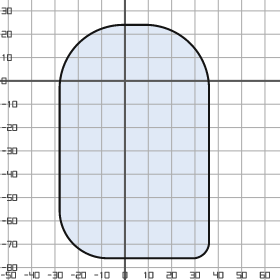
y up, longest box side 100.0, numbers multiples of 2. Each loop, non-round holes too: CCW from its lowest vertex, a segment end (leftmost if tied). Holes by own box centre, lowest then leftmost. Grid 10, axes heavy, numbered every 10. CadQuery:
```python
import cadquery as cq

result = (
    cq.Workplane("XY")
    .moveTo(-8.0, -76.0)
    .lineTo(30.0, -76.0)
    .threePointArc((34.0, -74.0), (36.0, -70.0))
    .lineTo(36.0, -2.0)
    .threePointArc((28.0, 16.0), (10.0, 24.0))
    .lineTo(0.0, 24.0)
    .threePointArc((-20.0, 16.0), (-28.0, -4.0))
    .lineTo(-28.0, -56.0)
    .threePointArc((-22.0, -70.0), (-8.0, -76.0))
    .close()
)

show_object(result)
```